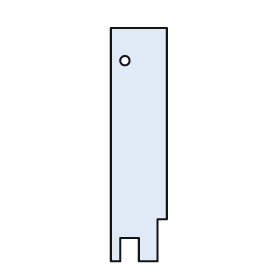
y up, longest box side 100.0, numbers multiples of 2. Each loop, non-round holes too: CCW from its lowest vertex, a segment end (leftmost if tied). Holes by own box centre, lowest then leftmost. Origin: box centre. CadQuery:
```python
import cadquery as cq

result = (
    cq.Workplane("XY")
    .moveTo(-12.0, -50.0)
    .lineTo(-8.0, -50.0)
    .lineTo(-8.0, -40.0)
    .lineTo(0.0, -40.0)
    .lineTo(0.0, -50.0)
    .lineTo(8.0, -50.0)
    .lineTo(8.0, -32.0)
    .lineTo(12.0, -32.0)
    .lineTo(12.0, 50.0)
    .lineTo(-12.0, 50.0)
    .close()
    .moveTo(-6.0, 36.0)
    .circle(2.0)
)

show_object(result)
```